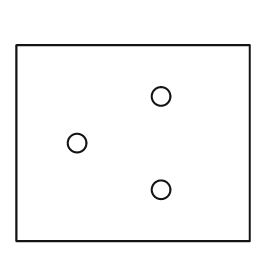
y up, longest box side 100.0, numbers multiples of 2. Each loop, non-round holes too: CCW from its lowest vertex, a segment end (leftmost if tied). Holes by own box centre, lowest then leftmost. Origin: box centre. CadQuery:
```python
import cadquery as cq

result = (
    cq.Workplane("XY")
    .moveTo(-50.0, -42.0)
    .lineTo(50.0, -42.0)
    .lineTo(50.0, 42.0)
    .lineTo(-50.0, 42.0)
    .close()
    .moveTo(12.0, -20.0)
    .circle(4.0)
    .moveTo(-24.0, 0.0)
    .circle(4.0)
    .moveTo(12.0, 20.0)
    .circle(4.0)
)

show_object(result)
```